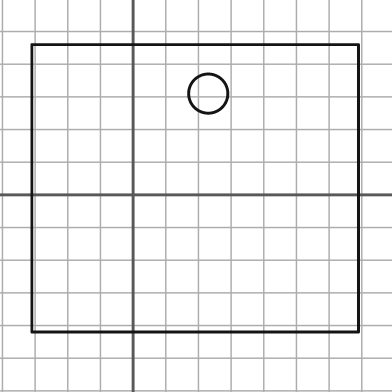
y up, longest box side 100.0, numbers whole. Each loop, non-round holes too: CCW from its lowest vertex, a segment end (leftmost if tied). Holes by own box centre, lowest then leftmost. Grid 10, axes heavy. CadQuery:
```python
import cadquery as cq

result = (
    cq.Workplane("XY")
    .moveTo(-31.0, -42.0)
    .lineTo(69.0, -42.0)
    .lineTo(69.0, 46.0)
    .lineTo(-31.0, 46.0)
    .close()
    .moveTo(23.0, 31.0)
    .circle(6.0)
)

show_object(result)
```